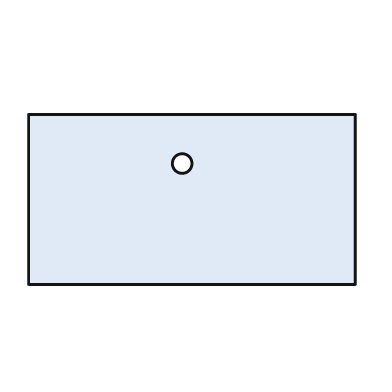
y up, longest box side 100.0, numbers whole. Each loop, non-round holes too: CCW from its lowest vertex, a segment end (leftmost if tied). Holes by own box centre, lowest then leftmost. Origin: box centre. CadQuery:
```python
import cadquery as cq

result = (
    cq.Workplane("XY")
    .moveTo(-50.0, -26.0)
    .lineTo(50.0, -26.0)
    .lineTo(50.0, 26.0)
    .lineTo(-50.0, 26.0)
    .close()
    .moveTo(-3.0, 11.0)
    .circle(3.0)
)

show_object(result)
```